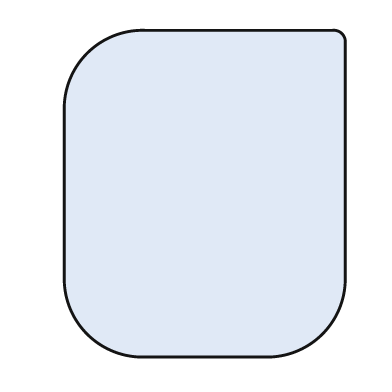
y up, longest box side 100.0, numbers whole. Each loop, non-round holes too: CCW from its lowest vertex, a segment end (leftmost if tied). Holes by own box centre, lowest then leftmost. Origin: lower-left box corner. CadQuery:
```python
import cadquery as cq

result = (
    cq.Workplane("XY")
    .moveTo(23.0, 0.0)
    .lineTo(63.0, 0.0)
    .threePointArc((79.0, 7.0), (86.0, 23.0))
    .lineTo(86.0, 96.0)
    .threePointArc((85.0, 99.0), (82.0, 100.0))
    .lineTo(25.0, 100.0)
    .threePointArc((7.0, 93.0), (0.0, 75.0))
    .lineTo(0.0, 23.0)
    .threePointArc((7.0, 7.0), (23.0, 0.0))
    .close()
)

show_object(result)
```